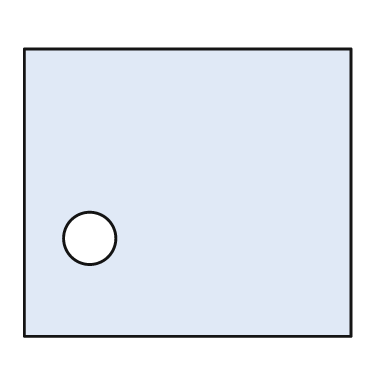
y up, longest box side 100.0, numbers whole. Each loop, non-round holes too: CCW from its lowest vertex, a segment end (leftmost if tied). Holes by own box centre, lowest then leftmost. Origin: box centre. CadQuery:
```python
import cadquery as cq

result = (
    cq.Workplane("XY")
    .moveTo(-50.0, -44.0)
    .lineTo(50.0, -44.0)
    .lineTo(50.0, 44.0)
    .lineTo(-50.0, 44.0)
    .close()
    .moveTo(-30.0, -14.0)
    .circle(8.0)
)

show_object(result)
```